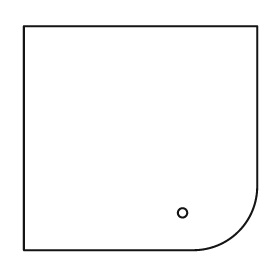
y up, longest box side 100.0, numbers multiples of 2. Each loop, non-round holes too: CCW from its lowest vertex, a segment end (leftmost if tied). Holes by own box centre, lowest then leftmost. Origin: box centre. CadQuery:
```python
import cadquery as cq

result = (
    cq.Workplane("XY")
    .moveTo(-50.0, -48.0)
    .lineTo(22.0, -48.0)
    .threePointArc((42.0, -40.0), (50.0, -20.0))
    .lineTo(50.0, 48.0)
    .lineTo(-50.0, 48.0)
    .close()
    .moveTo(18.0, -32.0)
    .circle(2.0)
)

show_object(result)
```